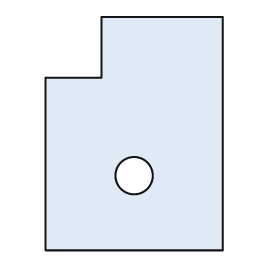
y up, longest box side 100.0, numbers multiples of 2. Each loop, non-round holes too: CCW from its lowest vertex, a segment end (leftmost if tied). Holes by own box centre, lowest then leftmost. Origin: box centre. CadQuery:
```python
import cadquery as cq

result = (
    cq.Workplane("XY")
    .moveTo(-38.0, -50.0)
    .lineTo(38.0, -50.0)
    .lineTo(38.0, 50.0)
    .lineTo(-14.0, 50.0)
    .lineTo(-14.0, 24.0)
    .lineTo(-38.0, 24.0)
    .close()
    .moveTo(0.0, -18.0)
    .circle(8.0)
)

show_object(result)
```